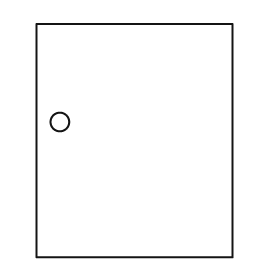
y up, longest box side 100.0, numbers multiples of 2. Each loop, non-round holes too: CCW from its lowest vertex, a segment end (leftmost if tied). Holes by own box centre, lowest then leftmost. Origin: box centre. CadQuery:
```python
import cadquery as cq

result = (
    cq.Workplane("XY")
    .moveTo(-42.0, -50.0)
    .lineTo(42.0, -50.0)
    .lineTo(42.0, 50.0)
    .lineTo(-42.0, 50.0)
    .close()
    .moveTo(-32.0, 8.0)
    .circle(4.0)
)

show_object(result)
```